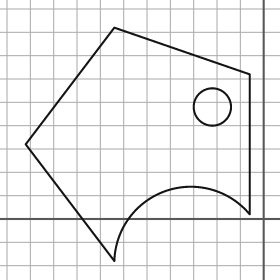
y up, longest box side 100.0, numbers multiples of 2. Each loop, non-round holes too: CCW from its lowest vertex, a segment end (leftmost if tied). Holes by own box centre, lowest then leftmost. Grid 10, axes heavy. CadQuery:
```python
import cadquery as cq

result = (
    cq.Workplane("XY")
    .moveTo(-64.0, -18.0)
    .threePointArc((-42.0, 12.0), (-6.0, 2.0))
    .lineTo(-6.0, 62.0)
    .lineTo(-64.0, 82.0)
    .lineTo(-102.0, 32.0)
    .close()
    .moveTo(-22.0, 48.0)
    .circle(8.0)
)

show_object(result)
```